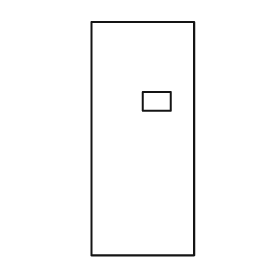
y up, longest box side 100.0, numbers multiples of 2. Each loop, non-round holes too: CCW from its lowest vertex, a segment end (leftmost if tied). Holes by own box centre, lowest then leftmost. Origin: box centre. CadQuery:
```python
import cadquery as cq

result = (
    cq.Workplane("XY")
    .moveTo(-22.0, -50.0)
    .lineTo(22.0, -50.0)
    .lineTo(22.0, 50.0)
    .lineTo(-22.0, 50.0)
    .close()
    .moveTo(0.0, 12.0)
    .lineTo(12.0, 12.0)
    .lineTo(12.0, 20.0)
    .lineTo(0.0, 20.0)
    .close()
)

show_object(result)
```